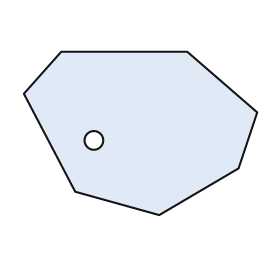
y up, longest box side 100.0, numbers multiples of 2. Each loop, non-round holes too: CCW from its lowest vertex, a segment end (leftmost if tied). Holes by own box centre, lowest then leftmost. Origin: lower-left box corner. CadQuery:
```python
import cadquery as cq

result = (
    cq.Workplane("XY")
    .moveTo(58.0, 0.0)
    .lineTo(92.0, 20.0)
    .lineTo(100.0, 44.0)
    .lineTo(70.0, 70.0)
    .lineTo(16.0, 70.0)
    .lineTo(0.0, 52.0)
    .lineTo(22.0, 10.0)
    .close()
    .moveTo(30.0, 32.0)
    .circle(4.0)
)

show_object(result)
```